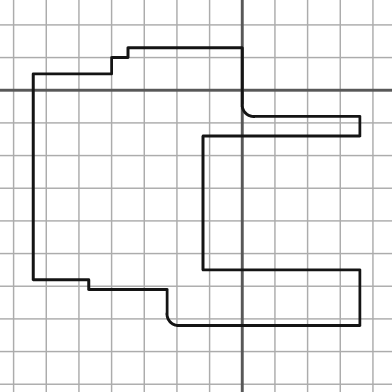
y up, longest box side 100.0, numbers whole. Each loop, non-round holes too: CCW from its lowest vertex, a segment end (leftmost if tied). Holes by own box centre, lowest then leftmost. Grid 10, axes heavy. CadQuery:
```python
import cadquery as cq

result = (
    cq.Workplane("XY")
    .moveTo(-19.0, -72.0)
    .lineTo(36.0, -72.0)
    .lineTo(36.0, -55.0)
    .lineTo(-12.0, -55.0)
    .lineTo(-12.0, -14.0)
    .lineTo(36.0, -14.0)
    .lineTo(36.0, -8.0)
    .lineTo(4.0, -8.0)
    .threePointArc((1.0, -7.0), (0.0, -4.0))
    .lineTo(0.0, 13.0)
    .lineTo(-35.0, 13.0)
    .lineTo(-35.0, 10.0)
    .lineTo(-40.0, 10.0)
    .lineTo(-40.0, 5.0)
    .lineTo(-64.0, 5.0)
    .lineTo(-64.0, -58.0)
    .lineTo(-47.0, -58.0)
    .lineTo(-47.0, -61.0)
    .lineTo(-23.0, -61.0)
    .lineTo(-23.0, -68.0)
    .threePointArc((-22.0, -71.0), (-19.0, -72.0))
    .close()
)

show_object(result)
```